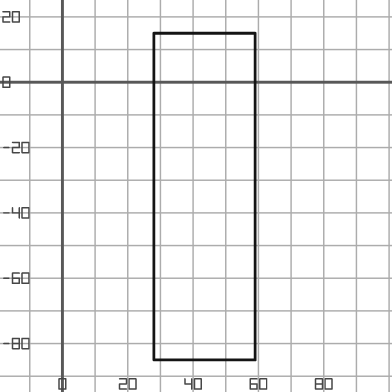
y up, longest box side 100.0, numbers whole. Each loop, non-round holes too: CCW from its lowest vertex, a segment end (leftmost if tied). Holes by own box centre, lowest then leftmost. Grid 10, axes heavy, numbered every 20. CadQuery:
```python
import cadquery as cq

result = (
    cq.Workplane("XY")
    .moveTo(28.0, -85.0)
    .lineTo(59.0, -85.0)
    .lineTo(59.0, 15.0)
    .lineTo(28.0, 15.0)
    .close()
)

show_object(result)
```